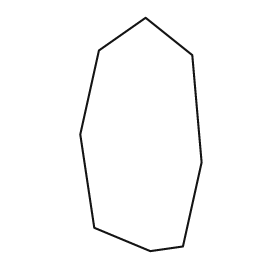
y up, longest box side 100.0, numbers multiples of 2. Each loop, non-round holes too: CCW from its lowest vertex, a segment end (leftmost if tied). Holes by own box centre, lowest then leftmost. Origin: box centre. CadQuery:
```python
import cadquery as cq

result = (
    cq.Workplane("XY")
    .moveTo(4.0, -50.0)
    .lineTo(18.0, -48.0)
    .lineTo(26.0, -12.0)
    .lineTo(22.0, 34.0)
    .lineTo(2.0, 50.0)
    .lineTo(-18.0, 36.0)
    .lineTo(-26.0, 0.0)
    .lineTo(-20.0, -40.0)
    .close()
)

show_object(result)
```